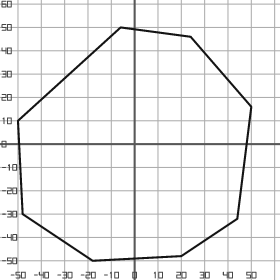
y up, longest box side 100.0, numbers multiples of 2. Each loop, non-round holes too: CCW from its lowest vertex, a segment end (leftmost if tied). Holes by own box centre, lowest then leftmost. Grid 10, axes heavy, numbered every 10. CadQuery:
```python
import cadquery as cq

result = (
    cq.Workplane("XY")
    .moveTo(-18.0, -50.0)
    .lineTo(20.0, -48.0)
    .lineTo(44.0, -32.0)
    .lineTo(50.0, 16.0)
    .lineTo(24.0, 46.0)
    .lineTo(-6.0, 50.0)
    .lineTo(-50.0, 10.0)
    .lineTo(-48.0, -30.0)
    .close()
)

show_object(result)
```